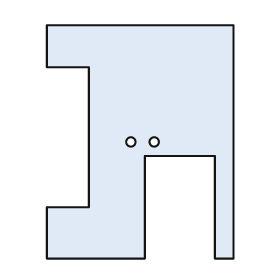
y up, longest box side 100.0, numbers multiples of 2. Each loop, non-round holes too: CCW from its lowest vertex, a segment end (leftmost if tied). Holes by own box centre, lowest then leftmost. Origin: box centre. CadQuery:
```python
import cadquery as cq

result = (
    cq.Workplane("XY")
    .moveTo(-40.0, -50.0)
    .lineTo(2.0, -50.0)
    .lineTo(2.0, -6.0)
    .lineTo(32.0, -6.0)
    .lineTo(32.0, -50.0)
    .lineTo(40.0, -50.0)
    .lineTo(40.0, 50.0)
    .lineTo(-40.0, 50.0)
    .lineTo(-40.0, 32.0)
    .lineTo(-22.0, 32.0)
    .lineTo(-22.0, -28.0)
    .lineTo(-40.0, -28.0)
    .close()
    .moveTo(-4.0, 0.0)
    .circle(2.0)
    .moveTo(6.0, 0.0)
    .circle(2.0)
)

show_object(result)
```